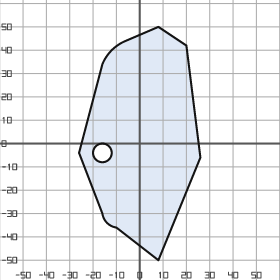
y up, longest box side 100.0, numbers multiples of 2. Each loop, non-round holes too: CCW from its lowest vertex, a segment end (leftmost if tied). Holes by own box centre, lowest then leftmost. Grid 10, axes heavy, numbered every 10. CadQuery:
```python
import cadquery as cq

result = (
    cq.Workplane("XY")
    .moveTo(8.0, -50.0)
    .lineTo(26.0, -6.0)
    .lineTo(20.0, 42.0)
    .lineTo(8.0, 50.0)
    .lineTo(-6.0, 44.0)
    .threePointArc((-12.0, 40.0), (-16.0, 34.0))
    .lineTo(-26.0, -4.0)
    .lineTo(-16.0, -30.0)
    .threePointArc((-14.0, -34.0), (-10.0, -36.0))
    .close()
    .moveTo(-16.0, -4.0)
    .circle(4.0)
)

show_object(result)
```